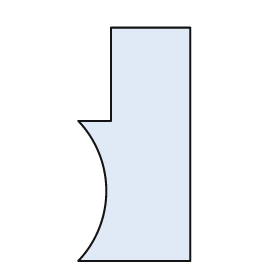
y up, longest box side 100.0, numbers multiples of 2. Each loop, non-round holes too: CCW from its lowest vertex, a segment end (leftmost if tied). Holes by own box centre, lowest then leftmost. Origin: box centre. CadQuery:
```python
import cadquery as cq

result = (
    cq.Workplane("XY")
    .moveTo(-24.0, -50.0)
    .lineTo(24.0, -50.0)
    .lineTo(24.0, 50.0)
    .lineTo(-10.0, 50.0)
    .lineTo(-10.0, 10.0)
    .lineTo(-24.0, 10.0)
    .threePointArc((-12.0, -20.0), (-24.0, -50.0))
    .close()
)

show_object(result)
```